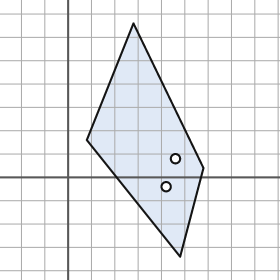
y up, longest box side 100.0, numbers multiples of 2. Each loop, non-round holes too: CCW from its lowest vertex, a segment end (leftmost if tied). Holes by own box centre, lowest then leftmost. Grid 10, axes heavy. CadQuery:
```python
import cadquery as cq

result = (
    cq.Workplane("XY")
    .moveTo(48.0, -34.0)
    .lineTo(58.0, 4.0)
    .lineTo(28.0, 66.0)
    .lineTo(8.0, 16.0)
    .close()
    .moveTo(42.0, -4.0)
    .circle(2.0)
    .moveTo(46.0, 8.0)
    .circle(2.0)
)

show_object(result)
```